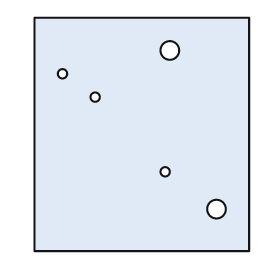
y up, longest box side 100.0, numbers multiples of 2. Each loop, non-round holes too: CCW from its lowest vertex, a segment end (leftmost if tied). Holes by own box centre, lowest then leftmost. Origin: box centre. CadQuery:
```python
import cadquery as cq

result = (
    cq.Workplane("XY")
    .moveTo(-46.0, -50.0)
    .lineTo(46.0, -50.0)
    .lineTo(46.0, 50.0)
    .lineTo(-46.0, 50.0)
    .close()
    .moveTo(32.0, -32.0)
    .circle(4.0)
    .moveTo(10.0, -16.0)
    .circle(2.0)
    .moveTo(-20.0, 16.0)
    .circle(2.0)
    .moveTo(-34.0, 26.0)
    .circle(2.0)
    .moveTo(12.0, 36.0)
    .circle(4.0)
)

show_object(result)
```